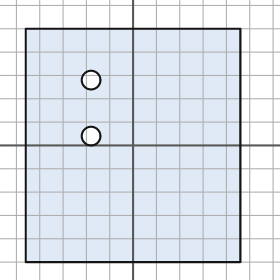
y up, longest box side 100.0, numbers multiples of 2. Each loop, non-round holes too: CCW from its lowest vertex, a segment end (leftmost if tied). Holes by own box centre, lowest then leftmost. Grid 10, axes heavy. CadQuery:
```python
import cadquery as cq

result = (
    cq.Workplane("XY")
    .moveTo(-46.0, -50.0)
    .lineTo(46.0, -50.0)
    .lineTo(46.0, 50.0)
    .lineTo(-46.0, 50.0)
    .close()
    .moveTo(-18.0, 4.0)
    .circle(4.0)
    .moveTo(-18.0, 28.0)
    .circle(4.0)
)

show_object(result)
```